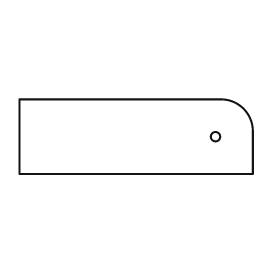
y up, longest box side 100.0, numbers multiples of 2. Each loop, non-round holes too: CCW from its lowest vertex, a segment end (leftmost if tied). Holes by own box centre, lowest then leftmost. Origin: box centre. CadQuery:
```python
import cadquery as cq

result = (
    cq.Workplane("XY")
    .moveTo(-50.0, -16.0)
    .lineTo(50.0, -16.0)
    .lineTo(50.0, 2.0)
    .threePointArc((46.0, 12.0), (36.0, 16.0))
    .lineTo(-50.0, 16.0)
    .close()
    .moveTo(34.0, 0.0)
    .circle(2.0)
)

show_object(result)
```